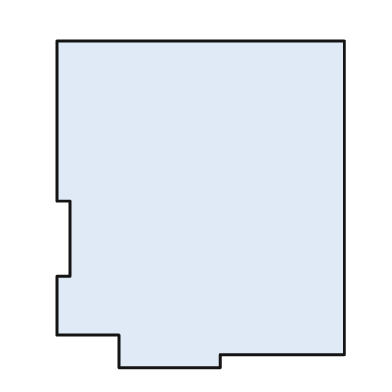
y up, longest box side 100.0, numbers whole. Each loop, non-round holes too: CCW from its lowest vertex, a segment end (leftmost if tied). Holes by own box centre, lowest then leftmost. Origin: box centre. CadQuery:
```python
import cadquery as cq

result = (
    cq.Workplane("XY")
    .moveTo(-25.0, -50.0)
    .lineTo(6.0, -50.0)
    .lineTo(6.0, -46.0)
    .lineTo(44.0, -46.0)
    .lineTo(44.0, 50.0)
    .lineTo(-44.0, 50.0)
    .lineTo(-44.0, 1.0)
    .lineTo(-40.0, 1.0)
    .lineTo(-40.0, -22.0)
    .lineTo(-44.0, -22.0)
    .lineTo(-44.0, -40.0)
    .lineTo(-25.0, -40.0)
    .close()
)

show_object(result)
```